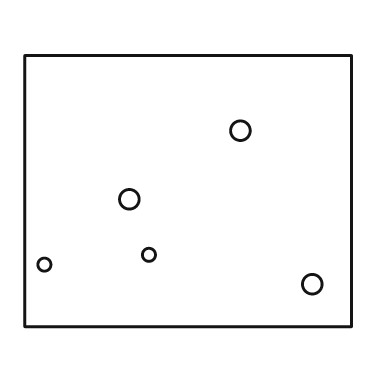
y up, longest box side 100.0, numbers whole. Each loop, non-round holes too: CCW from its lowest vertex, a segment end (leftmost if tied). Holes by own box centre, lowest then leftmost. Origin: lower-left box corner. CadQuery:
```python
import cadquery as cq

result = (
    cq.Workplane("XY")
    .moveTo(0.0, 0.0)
    .lineTo(100.0, 0.0)
    .lineTo(100.0, 83.0)
    .lineTo(0.0, 83.0)
    .close()
    .moveTo(88.0, 13.0)
    .circle(3.0)
    .moveTo(6.0, 19.0)
    .circle(2.0)
    .moveTo(38.0, 22.0)
    .circle(2.0)
    .moveTo(32.0, 39.0)
    .circle(3.0)
    .moveTo(66.0, 60.0)
    .circle(3.0)
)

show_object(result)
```